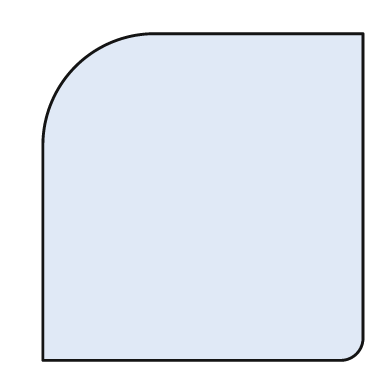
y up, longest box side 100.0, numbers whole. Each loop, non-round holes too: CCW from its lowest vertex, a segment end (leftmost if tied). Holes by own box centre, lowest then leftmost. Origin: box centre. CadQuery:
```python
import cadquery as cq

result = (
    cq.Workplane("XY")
    .moveTo(-49.0, -50.0)
    .lineTo(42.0, -50.0)
    .threePointArc((47.0, -48.0), (49.0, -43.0))
    .lineTo(49.0, 50.0)
    .lineTo(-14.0, 50.0)
    .threePointArc((-39.0, 40.0), (-49.0, 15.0))
    .close()
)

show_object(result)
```